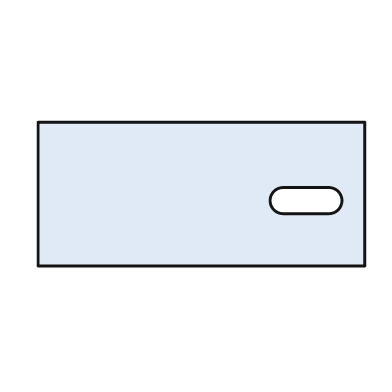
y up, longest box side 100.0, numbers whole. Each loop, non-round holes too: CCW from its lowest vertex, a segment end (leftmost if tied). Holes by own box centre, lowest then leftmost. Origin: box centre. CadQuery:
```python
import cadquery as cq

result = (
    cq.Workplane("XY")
    .moveTo(-50.0, -22.0)
    .lineTo(50.0, -22.0)
    .lineTo(50.0, 22.0)
    .lineTo(-50.0, 22.0)
    .close()
    .moveTo(25.0, -6.0)
    .lineTo(39.0, -6.0)
    .threePointArc((43.0, -2.0), (39.0, 2.0))
    .lineTo(25.0, 2.0)
    .threePointArc((21.0, -2.0), (25.0, -6.0))
    .close()
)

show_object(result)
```